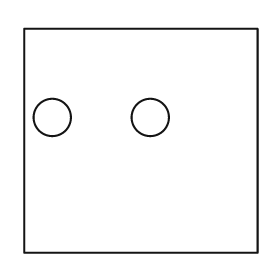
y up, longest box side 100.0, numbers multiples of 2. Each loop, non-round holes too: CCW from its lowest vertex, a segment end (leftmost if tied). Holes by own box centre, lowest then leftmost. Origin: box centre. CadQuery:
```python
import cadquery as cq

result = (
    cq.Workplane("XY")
    .moveTo(-50.0, -48.0)
    .lineTo(50.0, -48.0)
    .lineTo(50.0, 48.0)
    .lineTo(-50.0, 48.0)
    .close()
    .moveTo(-38.0, 10.0)
    .circle(8.0)
    .moveTo(4.0, 10.0)
    .circle(8.0)
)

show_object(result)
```